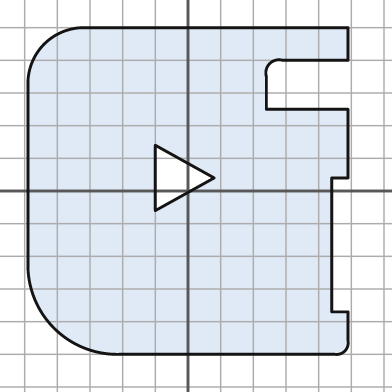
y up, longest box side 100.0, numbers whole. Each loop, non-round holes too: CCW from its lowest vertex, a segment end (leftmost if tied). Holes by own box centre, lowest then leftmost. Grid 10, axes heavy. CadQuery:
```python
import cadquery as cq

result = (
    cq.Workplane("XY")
    .moveTo(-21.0, -50.0)
    .lineTo(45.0, -50.0)
    .threePointArc((48.0, -49.0), (49.0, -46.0))
    .lineTo(49.0, -37.0)
    .lineTo(44.0, -37.0)
    .lineTo(44.0, 4.0)
    .lineTo(49.0, 4.0)
    .lineTo(49.0, 25.0)
    .lineTo(24.0, 25.0)
    .lineTo(24.0, 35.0)
    .threePointArc((25.0, 39.0), (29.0, 40.0))
    .lineTo(49.0, 40.0)
    .lineTo(49.0, 50.0)
    .lineTo(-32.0, 50.0)
    .threePointArc((-44.0, 45.0), (-49.0, 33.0))
    .lineTo(-49.0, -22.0)
    .threePointArc((-41.0, -42.0), (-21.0, -50.0))
    .close()
    .moveTo(-10.0, -6.0)
    .lineTo(8.0, 4.0)
    .lineTo(-10.0, 14.0)
    .close()
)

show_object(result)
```